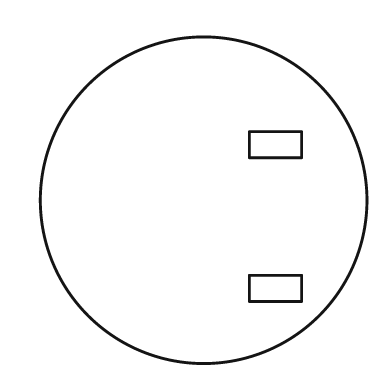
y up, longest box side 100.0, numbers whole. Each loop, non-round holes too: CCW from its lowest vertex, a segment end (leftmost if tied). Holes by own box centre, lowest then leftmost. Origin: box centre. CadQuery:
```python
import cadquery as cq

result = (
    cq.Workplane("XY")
    .moveTo(0.0, 0.0)
    .circle(50.0)
    .moveTo(14.0, -31.0)
    .lineTo(30.0, -31.0)
    .lineTo(30.0, -23.0)
    .lineTo(14.0, -23.0)
    .close()
    .moveTo(14.0, 13.0)
    .lineTo(30.0, 13.0)
    .lineTo(30.0, 21.0)
    .lineTo(14.0, 21.0)
    .close()
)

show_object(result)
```